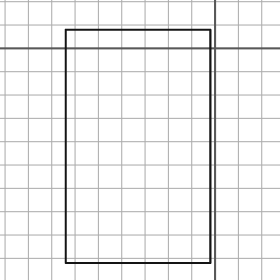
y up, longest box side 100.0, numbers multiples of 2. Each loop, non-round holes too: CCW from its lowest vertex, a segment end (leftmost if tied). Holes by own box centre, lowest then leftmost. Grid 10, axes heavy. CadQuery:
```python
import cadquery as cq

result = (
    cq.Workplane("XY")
    .moveTo(-64.0, -92.0)
    .lineTo(-2.0, -92.0)
    .lineTo(-2.0, 8.0)
    .lineTo(-64.0, 8.0)
    .close()
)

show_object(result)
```